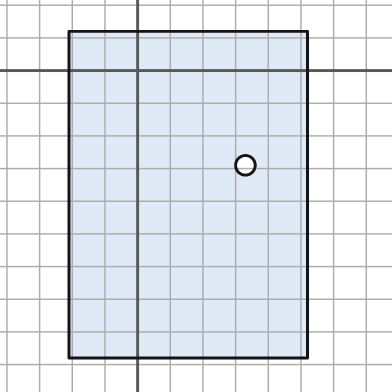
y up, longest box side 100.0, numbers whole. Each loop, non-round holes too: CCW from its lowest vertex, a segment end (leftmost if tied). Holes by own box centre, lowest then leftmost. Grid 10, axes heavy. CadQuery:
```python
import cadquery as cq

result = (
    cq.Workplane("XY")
    .moveTo(-21.0, -88.0)
    .lineTo(52.0, -88.0)
    .lineTo(52.0, 12.0)
    .lineTo(-21.0, 12.0)
    .close()
    .moveTo(33.0, -29.0)
    .circle(3.0)
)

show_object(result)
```